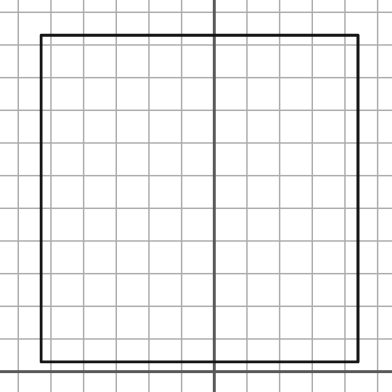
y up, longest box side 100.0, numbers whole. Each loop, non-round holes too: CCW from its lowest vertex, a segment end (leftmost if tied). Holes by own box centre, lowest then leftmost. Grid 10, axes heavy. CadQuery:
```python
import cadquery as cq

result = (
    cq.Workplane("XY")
    .moveTo(-53.0, 3.0)
    .lineTo(44.0, 3.0)
    .lineTo(44.0, 103.0)
    .lineTo(-53.0, 103.0)
    .close()
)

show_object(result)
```